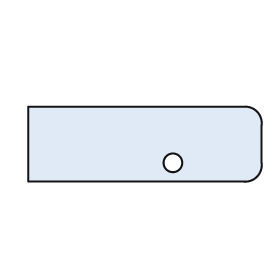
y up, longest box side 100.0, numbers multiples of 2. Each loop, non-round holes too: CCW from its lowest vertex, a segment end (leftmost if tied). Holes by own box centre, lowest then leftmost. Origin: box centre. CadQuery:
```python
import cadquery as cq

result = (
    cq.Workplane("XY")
    .moveTo(-50.0, -16.0)
    .lineTo(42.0, -16.0)
    .threePointArc((48.0, -14.0), (50.0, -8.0))
    .lineTo(50.0, 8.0)
    .threePointArc((48.0, 14.0), (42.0, 16.0))
    .lineTo(-50.0, 16.0)
    .close()
    .moveTo(12.0, -8.0)
    .circle(4.0)
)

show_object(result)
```